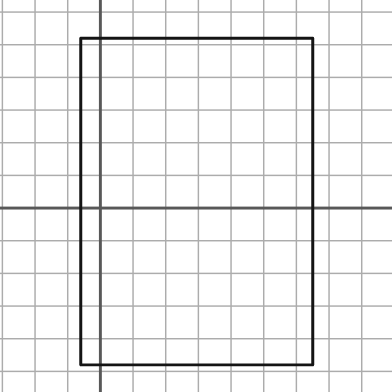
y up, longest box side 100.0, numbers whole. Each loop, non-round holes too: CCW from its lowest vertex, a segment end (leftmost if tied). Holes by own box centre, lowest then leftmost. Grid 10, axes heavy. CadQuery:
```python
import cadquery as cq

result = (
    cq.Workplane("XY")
    .moveTo(-6.0, -48.0)
    .lineTo(65.0, -48.0)
    .lineTo(65.0, 52.0)
    .lineTo(-6.0, 52.0)
    .close()
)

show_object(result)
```